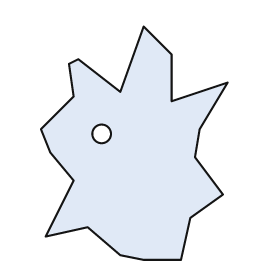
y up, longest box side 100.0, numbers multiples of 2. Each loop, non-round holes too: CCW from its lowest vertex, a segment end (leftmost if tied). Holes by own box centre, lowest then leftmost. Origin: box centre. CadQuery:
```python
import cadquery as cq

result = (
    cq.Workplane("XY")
    .moveTo(4.0, -50.0)
    .lineTo(20.0, -50.0)
    .lineTo(24.0, -32.0)
    .lineTo(38.0, -22.0)
    .lineTo(26.0, -6.0)
    .lineTo(28.0, 6.0)
    .lineTo(40.0, 26.0)
    .lineTo(16.0, 18.0)
    .lineTo(16.0, 38.0)
    .lineTo(4.0, 50.0)
    .lineTo(-6.0, 22.0)
    .lineTo(-24.0, 36.0)
    .lineTo(-28.0, 34.0)
    .lineTo(-26.0, 20.0)
    .lineTo(-40.0, 6.0)
    .lineTo(-36.0, -4.0)
    .lineTo(-26.0, -16.0)
    .lineTo(-38.0, -40.0)
    .lineTo(-20.0, -36.0)
    .lineTo(-6.0, -48.0)
    .close()
    .moveTo(-14.0, 4.0)
    .circle(4.0)
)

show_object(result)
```